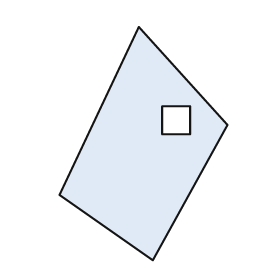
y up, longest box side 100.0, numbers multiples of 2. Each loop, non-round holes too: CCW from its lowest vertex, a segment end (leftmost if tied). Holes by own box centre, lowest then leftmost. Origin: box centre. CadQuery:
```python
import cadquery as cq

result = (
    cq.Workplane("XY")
    .moveTo(4.0, -50.0)
    .lineTo(36.0, 8.0)
    .lineTo(-2.0, 50.0)
    .lineTo(-36.0, -22.0)
    .close()
    .moveTo(8.0, 4.0)
    .lineTo(20.0, 4.0)
    .lineTo(20.0, 16.0)
    .lineTo(8.0, 16.0)
    .close()
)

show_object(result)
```